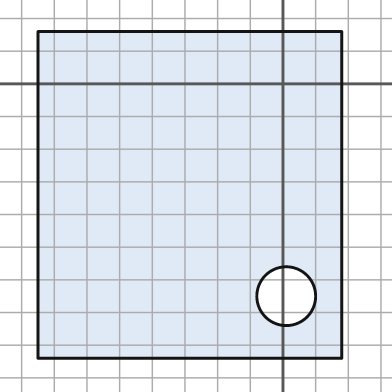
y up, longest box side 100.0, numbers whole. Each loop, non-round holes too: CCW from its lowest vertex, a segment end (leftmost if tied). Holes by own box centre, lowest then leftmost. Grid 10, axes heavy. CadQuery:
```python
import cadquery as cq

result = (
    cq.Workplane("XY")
    .moveTo(-75.0, -84.0)
    .lineTo(18.0, -84.0)
    .lineTo(18.0, 16.0)
    .lineTo(-75.0, 16.0)
    .close()
    .moveTo(1.0, -65.0)
    .circle(9.0)
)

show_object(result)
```